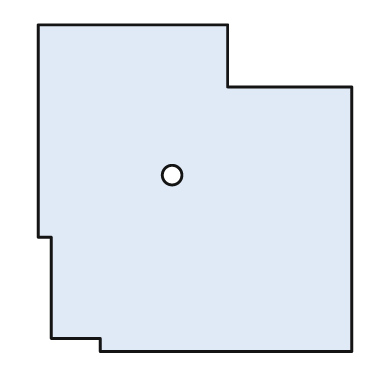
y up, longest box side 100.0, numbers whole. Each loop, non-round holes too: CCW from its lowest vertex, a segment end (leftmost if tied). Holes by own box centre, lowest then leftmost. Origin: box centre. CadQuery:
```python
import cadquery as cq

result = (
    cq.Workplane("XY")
    .moveTo(-29.0, -50.0)
    .lineTo(48.0, -50.0)
    .lineTo(48.0, 31.0)
    .lineTo(10.0, 31.0)
    .lineTo(10.0, 50.0)
    .lineTo(-48.0, 50.0)
    .lineTo(-48.0, -15.0)
    .lineTo(-44.0, -15.0)
    .lineTo(-44.0, -46.0)
    .lineTo(-29.0, -46.0)
    .close()
    .moveTo(-7.0, 4.0)
    .circle(3.0)
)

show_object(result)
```